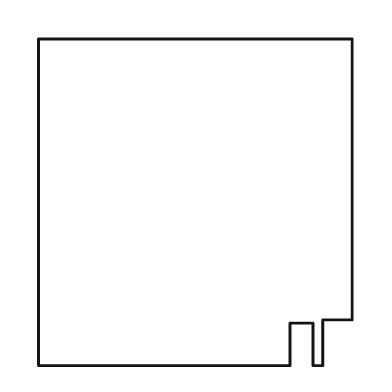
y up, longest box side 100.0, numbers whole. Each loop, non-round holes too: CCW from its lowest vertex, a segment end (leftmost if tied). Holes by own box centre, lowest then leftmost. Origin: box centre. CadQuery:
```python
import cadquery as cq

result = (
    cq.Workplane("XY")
    .moveTo(-48.0, -50.0)
    .lineTo(29.0, -50.0)
    .lineTo(29.0, -37.0)
    .lineTo(36.0, -37.0)
    .lineTo(36.0, -50.0)
    .lineTo(39.0, -50.0)
    .lineTo(39.0, -36.0)
    .lineTo(48.0, -36.0)
    .lineTo(48.0, 50.0)
    .lineTo(-48.0, 50.0)
    .close()
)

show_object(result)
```